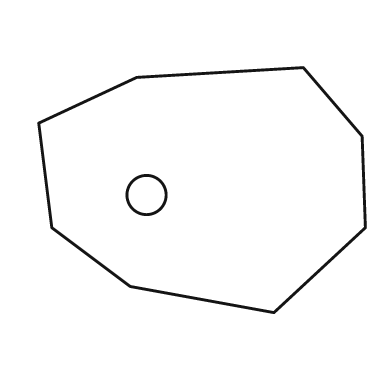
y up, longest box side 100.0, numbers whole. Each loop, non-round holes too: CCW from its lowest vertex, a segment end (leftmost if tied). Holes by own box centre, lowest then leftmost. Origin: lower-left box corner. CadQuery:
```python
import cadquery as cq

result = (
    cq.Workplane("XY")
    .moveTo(72.0, 0.0)
    .lineTo(100.0, 26.0)
    .lineTo(99.0, 54.0)
    .lineTo(81.0, 75.0)
    .lineTo(30.0, 72.0)
    .lineTo(0.0, 58.0)
    .lineTo(4.0, 26.0)
    .lineTo(28.0, 8.0)
    .close()
    .moveTo(33.0, 36.0)
    .circle(6.0)
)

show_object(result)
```